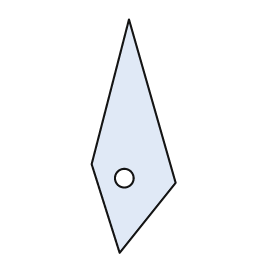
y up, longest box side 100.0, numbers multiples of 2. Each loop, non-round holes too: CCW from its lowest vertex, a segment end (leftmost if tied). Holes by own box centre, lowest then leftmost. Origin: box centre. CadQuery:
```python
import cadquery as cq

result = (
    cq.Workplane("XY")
    .moveTo(-6.0, -50.0)
    .lineTo(18.0, -20.0)
    .lineTo(-2.0, 50.0)
    .lineTo(-18.0, -12.0)
    .close()
    .moveTo(-4.0, -18.0)
    .circle(4.0)
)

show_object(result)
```